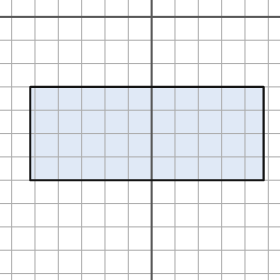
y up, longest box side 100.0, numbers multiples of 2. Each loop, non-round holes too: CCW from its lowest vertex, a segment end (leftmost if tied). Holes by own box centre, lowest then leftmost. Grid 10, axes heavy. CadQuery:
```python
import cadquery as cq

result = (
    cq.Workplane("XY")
    .moveTo(-52.0, -70.0)
    .lineTo(48.0, -70.0)
    .lineTo(48.0, -30.0)
    .lineTo(-52.0, -30.0)
    .close()
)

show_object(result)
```